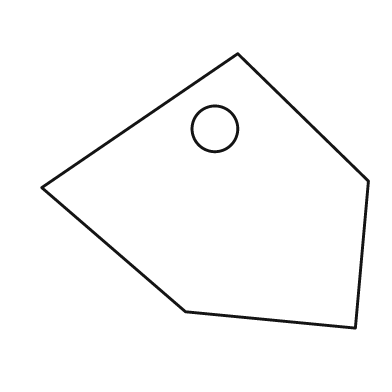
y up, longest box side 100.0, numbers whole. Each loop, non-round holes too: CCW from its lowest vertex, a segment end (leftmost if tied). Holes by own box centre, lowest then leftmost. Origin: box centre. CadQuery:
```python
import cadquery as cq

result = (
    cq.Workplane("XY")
    .moveTo(46.0, -42.0)
    .lineTo(50.0, 3.0)
    .lineTo(10.0, 42.0)
    .lineTo(-50.0, 1.0)
    .lineTo(-6.0, -37.0)
    .close()
    .moveTo(3.0, 19.0)
    .circle(7.0)
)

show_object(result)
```